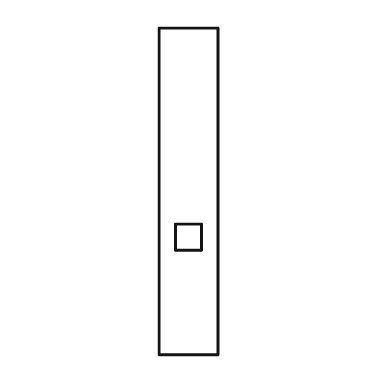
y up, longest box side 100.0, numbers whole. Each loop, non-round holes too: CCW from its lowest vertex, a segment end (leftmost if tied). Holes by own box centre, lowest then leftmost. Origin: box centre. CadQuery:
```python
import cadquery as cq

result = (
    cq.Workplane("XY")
    .moveTo(-9.0, -50.0)
    .lineTo(9.0, -50.0)
    .lineTo(9.0, 50.0)
    .lineTo(-9.0, 50.0)
    .close()
    .moveTo(-4.0, -18.0)
    .lineTo(4.0, -18.0)
    .lineTo(4.0, -10.0)
    .lineTo(-4.0, -10.0)
    .close()
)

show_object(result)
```